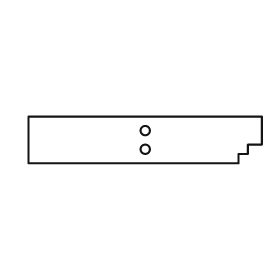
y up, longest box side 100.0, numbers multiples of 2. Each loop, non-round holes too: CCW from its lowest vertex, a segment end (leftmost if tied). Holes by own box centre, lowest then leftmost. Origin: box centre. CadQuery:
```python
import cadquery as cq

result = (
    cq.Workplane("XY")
    .moveTo(-50.0, -10.0)
    .lineTo(40.0, -10.0)
    .lineTo(40.0, -6.0)
    .lineTo(44.0, -6.0)
    .lineTo(44.0, -2.0)
    .lineTo(50.0, -2.0)
    .lineTo(50.0, 10.0)
    .lineTo(-50.0, 10.0)
    .close()
    .moveTo(0.0, -4.0)
    .circle(2.0)
    .moveTo(0.0, 4.0)
    .circle(2.0)
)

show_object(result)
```